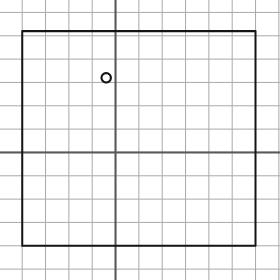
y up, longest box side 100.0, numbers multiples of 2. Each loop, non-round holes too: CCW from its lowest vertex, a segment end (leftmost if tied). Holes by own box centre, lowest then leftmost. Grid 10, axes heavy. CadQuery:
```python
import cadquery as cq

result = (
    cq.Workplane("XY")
    .moveTo(-40.0, -40.0)
    .lineTo(60.0, -40.0)
    .lineTo(60.0, 52.0)
    .lineTo(-40.0, 52.0)
    .close()
    .moveTo(-4.0, 32.0)
    .circle(2.0)
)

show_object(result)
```